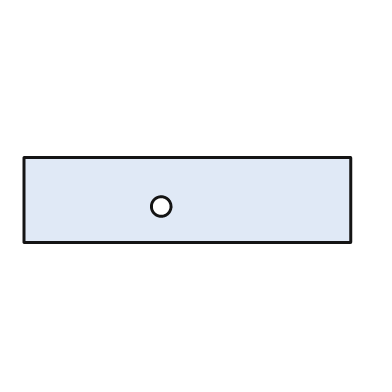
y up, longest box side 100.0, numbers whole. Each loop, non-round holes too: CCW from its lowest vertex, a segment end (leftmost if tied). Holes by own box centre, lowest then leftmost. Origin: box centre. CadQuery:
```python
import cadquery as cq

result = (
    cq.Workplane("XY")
    .moveTo(-50.0, -13.0)
    .lineTo(50.0, -13.0)
    .lineTo(50.0, 13.0)
    .lineTo(-50.0, 13.0)
    .close()
    .moveTo(-8.0, -2.0)
    .circle(3.0)
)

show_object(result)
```